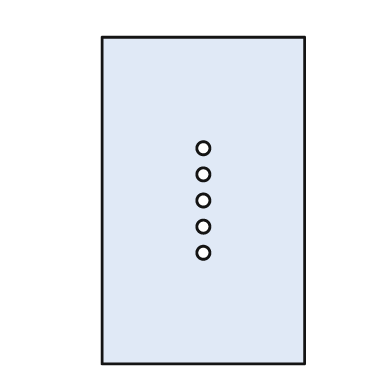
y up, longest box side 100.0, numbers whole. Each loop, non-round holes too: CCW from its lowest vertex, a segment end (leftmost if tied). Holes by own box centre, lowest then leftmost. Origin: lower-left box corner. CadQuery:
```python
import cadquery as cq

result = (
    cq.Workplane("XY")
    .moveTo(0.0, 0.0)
    .lineTo(62.0, 0.0)
    .lineTo(62.0, 100.0)
    .lineTo(0.0, 100.0)
    .close()
    .moveTo(31.0, 34.0)
    .circle(2.0)
    .moveTo(31.0, 42.0)
    .circle(2.0)
    .moveTo(31.0, 50.0)
    .circle(2.0)
    .moveTo(31.0, 58.0)
    .circle(2.0)
    .moveTo(31.0, 66.0)
    .circle(2.0)
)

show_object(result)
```